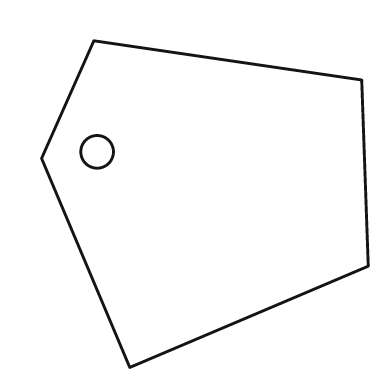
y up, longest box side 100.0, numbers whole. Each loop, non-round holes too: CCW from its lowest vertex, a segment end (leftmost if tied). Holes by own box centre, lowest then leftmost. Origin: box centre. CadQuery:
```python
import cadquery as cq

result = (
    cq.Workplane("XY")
    .moveTo(-23.0, -50.0)
    .lineTo(50.0, -19.0)
    .lineTo(48.0, 38.0)
    .lineTo(-34.0, 50.0)
    .lineTo(-50.0, 14.0)
    .close()
    .moveTo(-33.0, 16.0)
    .circle(5.0)
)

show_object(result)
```